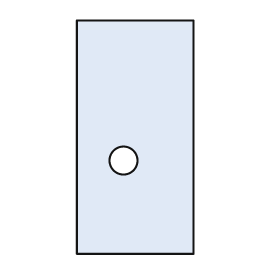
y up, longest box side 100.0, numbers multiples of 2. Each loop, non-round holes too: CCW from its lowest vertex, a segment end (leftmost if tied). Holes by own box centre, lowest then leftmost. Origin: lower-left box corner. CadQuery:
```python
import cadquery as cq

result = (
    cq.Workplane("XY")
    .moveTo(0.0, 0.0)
    .lineTo(50.0, 0.0)
    .lineTo(50.0, 100.0)
    .lineTo(0.0, 100.0)
    .close()
    .moveTo(20.0, 40.0)
    .circle(6.0)
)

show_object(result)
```